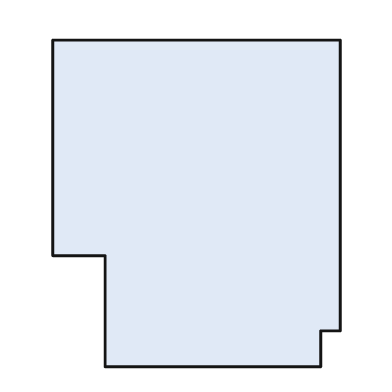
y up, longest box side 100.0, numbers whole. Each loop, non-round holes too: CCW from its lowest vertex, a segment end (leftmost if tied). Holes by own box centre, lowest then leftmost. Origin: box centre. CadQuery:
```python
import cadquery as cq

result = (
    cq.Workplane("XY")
    .moveTo(-28.0, -50.0)
    .lineTo(38.0, -50.0)
    .lineTo(38.0, -39.0)
    .lineTo(44.0, -39.0)
    .lineTo(44.0, 50.0)
    .lineTo(-44.0, 50.0)
    .lineTo(-44.0, -16.0)
    .lineTo(-28.0, -16.0)
    .close()
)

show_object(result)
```